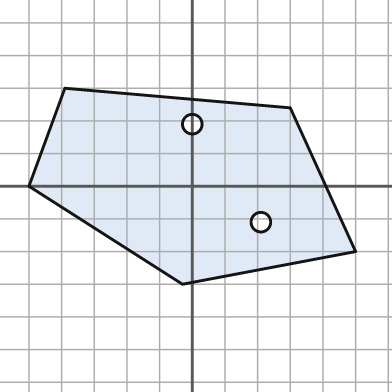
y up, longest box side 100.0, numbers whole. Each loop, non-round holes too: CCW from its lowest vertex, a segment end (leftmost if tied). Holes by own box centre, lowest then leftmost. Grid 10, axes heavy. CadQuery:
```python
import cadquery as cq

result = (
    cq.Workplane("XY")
    .moveTo(-3.0, -30.0)
    .lineTo(50.0, -20.0)
    .lineTo(30.0, 24.0)
    .lineTo(-39.0, 30.0)
    .lineTo(-50.0, 0.0)
    .close()
    .moveTo(21.0, -11.0)
    .circle(3.0)
    .moveTo(0.0, 19.0)
    .circle(3.0)
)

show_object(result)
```